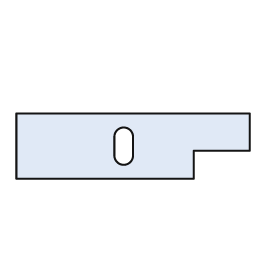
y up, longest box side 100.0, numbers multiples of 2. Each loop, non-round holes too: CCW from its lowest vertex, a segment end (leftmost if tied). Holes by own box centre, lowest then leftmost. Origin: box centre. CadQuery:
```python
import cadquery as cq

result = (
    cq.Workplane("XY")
    .moveTo(-50.0, -14.0)
    .lineTo(26.0, -14.0)
    .lineTo(26.0, -2.0)
    .lineTo(50.0, -2.0)
    .lineTo(50.0, 14.0)
    .lineTo(-50.0, 14.0)
    .close()
    .moveTo(-8.0, -4.0)
    .threePointArc((-4.0, -8.0), (0.0, -4.0))
    .lineTo(0.0, 4.0)
    .threePointArc((-4.0, 8.0), (-8.0, 4.0))
    .close()
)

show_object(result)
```